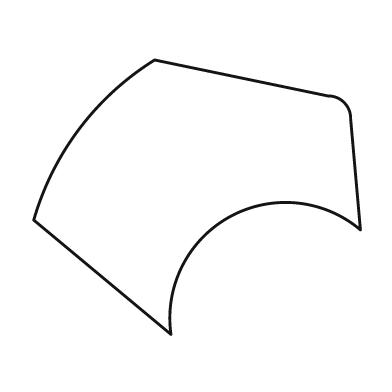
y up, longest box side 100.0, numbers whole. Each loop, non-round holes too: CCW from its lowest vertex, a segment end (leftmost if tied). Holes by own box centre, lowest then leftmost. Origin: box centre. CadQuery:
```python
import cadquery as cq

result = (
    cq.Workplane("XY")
    .moveTo(-8.0, -42.0)
    .threePointArc((10.0, -6.0), (50.0, -10.0))
    .lineTo(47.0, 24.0)
    .threePointArc((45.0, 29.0), (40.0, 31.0))
    .lineTo(-13.0, 42.0)
    .threePointArc((-36.0, 21.0), (-50.0, -7.0))
    .close()
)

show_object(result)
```